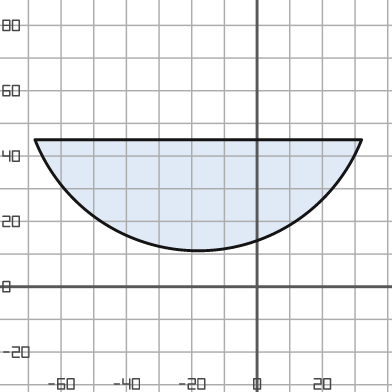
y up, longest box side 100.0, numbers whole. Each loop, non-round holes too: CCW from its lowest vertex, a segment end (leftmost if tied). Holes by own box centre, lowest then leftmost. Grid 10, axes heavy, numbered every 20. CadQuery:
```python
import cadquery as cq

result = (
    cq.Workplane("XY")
    .moveTo(-68.0, 45.0)
    .threePointArc((-18.0, 11.0), (32.0, 45.0))
    .close()
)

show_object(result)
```